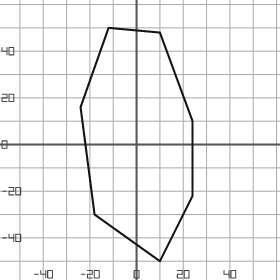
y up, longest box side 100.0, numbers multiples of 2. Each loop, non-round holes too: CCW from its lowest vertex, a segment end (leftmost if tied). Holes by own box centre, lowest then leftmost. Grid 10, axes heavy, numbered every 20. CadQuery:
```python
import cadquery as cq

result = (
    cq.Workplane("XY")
    .moveTo(10.0, -50.0)
    .lineTo(24.0, -22.0)
    .lineTo(24.0, 10.0)
    .lineTo(10.0, 48.0)
    .lineTo(-12.0, 50.0)
    .lineTo(-24.0, 16.0)
    .lineTo(-18.0, -30.0)
    .close()
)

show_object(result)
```